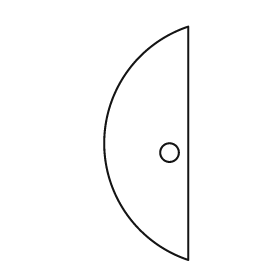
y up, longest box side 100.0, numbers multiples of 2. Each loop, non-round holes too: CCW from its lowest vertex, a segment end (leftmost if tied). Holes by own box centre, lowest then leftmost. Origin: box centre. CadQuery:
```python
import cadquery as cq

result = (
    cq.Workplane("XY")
    .moveTo(18.0, -50.0)
    .lineTo(18.0, 50.0)
    .threePointArc((-18.0, 0.0), (18.0, -50.0))
    .close()
    .moveTo(10.0, -4.0)
    .circle(4.0)
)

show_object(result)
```